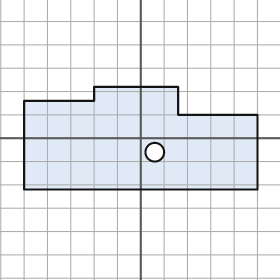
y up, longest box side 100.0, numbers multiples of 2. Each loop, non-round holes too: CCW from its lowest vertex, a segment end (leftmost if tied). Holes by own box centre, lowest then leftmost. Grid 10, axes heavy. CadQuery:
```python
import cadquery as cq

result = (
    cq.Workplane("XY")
    .moveTo(-50.0, -22.0)
    .lineTo(50.0, -22.0)
    .lineTo(50.0, 10.0)
    .lineTo(16.0, 10.0)
    .lineTo(16.0, 22.0)
    .lineTo(-20.0, 22.0)
    .lineTo(-20.0, 16.0)
    .lineTo(-50.0, 16.0)
    .close()
    .moveTo(6.0, -6.0)
    .circle(4.0)
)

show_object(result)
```